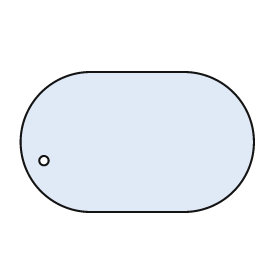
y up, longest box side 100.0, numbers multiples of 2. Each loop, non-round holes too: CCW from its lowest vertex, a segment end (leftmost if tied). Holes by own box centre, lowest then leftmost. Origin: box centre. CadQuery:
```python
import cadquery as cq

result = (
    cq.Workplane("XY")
    .moveTo(-20.0, -30.0)
    .lineTo(20.0, -30.0)
    .threePointArc((50.0, 0.0), (20.0, 30.0))
    .lineTo(-20.0, 30.0)
    .threePointArc((-50.0, 0.0), (-20.0, -30.0))
    .close()
    .moveTo(-40.0, -8.0)
    .circle(2.0)
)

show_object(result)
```